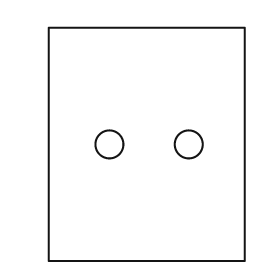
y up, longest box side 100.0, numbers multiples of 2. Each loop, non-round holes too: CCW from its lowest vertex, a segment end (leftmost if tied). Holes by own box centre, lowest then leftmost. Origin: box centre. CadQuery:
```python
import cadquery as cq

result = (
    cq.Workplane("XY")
    .moveTo(-42.0, -50.0)
    .lineTo(42.0, -50.0)
    .lineTo(42.0, 50.0)
    .lineTo(-42.0, 50.0)
    .close()
    .moveTo(-16.0, 0.0)
    .circle(6.0)
    .moveTo(18.0, 0.0)
    .circle(6.0)
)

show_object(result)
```